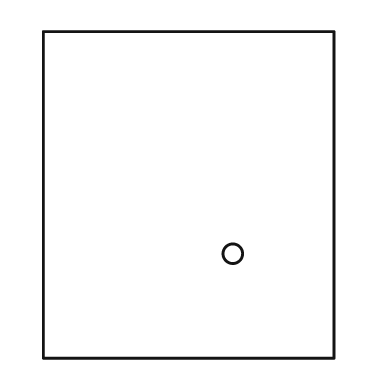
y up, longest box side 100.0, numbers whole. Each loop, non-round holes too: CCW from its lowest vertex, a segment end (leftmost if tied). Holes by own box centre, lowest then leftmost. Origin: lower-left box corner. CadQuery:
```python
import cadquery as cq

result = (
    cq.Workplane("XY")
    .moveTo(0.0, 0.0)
    .lineTo(89.0, 0.0)
    .lineTo(89.0, 100.0)
    .lineTo(0.0, 100.0)
    .close()
    .moveTo(58.0, 32.0)
    .circle(3.0)
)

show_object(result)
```